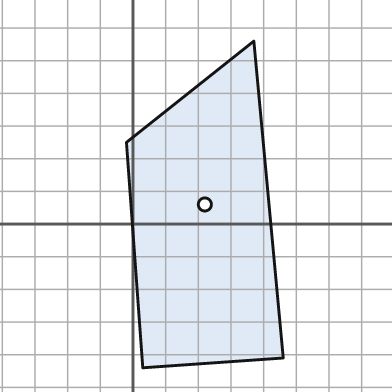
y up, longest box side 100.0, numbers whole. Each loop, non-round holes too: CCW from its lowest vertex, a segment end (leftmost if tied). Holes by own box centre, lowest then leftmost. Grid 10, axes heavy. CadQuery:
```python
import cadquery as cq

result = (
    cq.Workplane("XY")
    .moveTo(3.0, -44.0)
    .lineTo(46.0, -41.0)
    .lineTo(37.0, 56.0)
    .lineTo(-2.0, 25.0)
    .close()
    .moveTo(22.0, 6.0)
    .circle(2.0)
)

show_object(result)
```